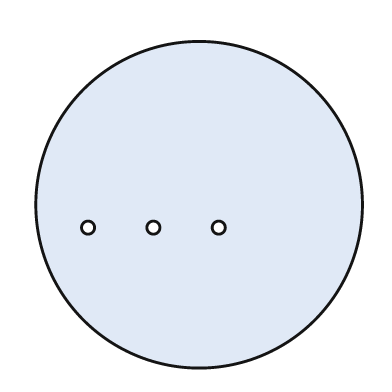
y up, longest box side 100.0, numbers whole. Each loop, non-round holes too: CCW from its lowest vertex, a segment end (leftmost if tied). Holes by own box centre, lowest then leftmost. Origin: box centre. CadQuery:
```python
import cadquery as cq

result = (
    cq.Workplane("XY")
    .moveTo(0.0, 0.0)
    .circle(50.0)
    .moveTo(-34.0, -7.0)
    .circle(2.0)
    .moveTo(-14.0, -7.0)
    .circle(2.0)
    .moveTo(6.0, -7.0)
    .circle(2.0)
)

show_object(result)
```